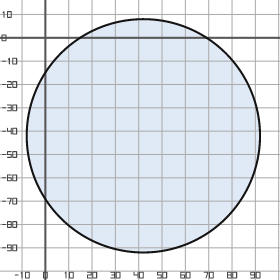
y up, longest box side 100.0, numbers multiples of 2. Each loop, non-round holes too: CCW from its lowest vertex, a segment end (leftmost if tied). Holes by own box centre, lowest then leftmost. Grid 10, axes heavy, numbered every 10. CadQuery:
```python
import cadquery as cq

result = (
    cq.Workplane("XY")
    .moveTo(42.0, -42.0)
    .circle(50.0)
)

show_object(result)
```